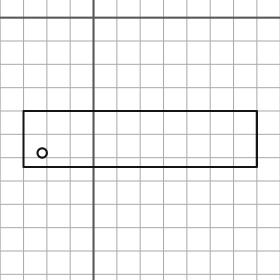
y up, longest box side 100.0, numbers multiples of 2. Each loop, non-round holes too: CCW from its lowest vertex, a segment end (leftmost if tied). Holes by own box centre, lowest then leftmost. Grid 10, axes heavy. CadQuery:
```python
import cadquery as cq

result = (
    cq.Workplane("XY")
    .moveTo(-30.0, -64.0)
    .lineTo(70.0, -64.0)
    .lineTo(70.0, -40.0)
    .lineTo(-30.0, -40.0)
    .close()
    .moveTo(-22.0, -58.0)
    .circle(2.0)
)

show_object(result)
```